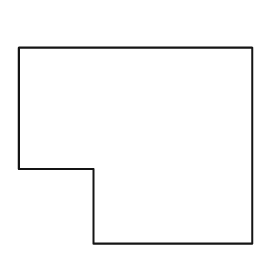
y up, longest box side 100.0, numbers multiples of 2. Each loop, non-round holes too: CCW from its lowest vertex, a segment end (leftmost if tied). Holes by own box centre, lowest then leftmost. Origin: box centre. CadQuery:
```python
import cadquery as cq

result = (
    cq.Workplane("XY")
    .moveTo(-18.0, -42.0)
    .lineTo(50.0, -42.0)
    .lineTo(50.0, 42.0)
    .lineTo(-50.0, 42.0)
    .lineTo(-50.0, -10.0)
    .lineTo(-18.0, -10.0)
    .close()
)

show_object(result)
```